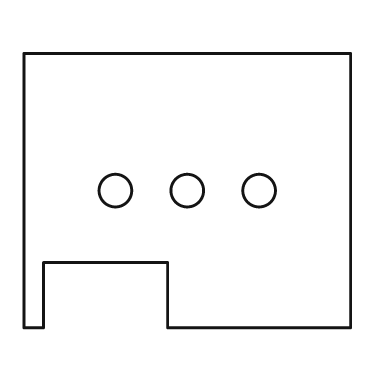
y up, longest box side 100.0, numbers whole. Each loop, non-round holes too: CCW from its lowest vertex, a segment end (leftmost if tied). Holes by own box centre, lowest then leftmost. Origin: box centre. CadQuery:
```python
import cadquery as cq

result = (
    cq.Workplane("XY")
    .moveTo(-50.0, -42.0)
    .lineTo(-44.0, -42.0)
    .lineTo(-44.0, -22.0)
    .lineTo(-6.0, -22.0)
    .lineTo(-6.0, -42.0)
    .lineTo(50.0, -42.0)
    .lineTo(50.0, 42.0)
    .lineTo(-50.0, 42.0)
    .close()
    .moveTo(-22.0, 0.0)
    .circle(5.0)
    .moveTo(0.0, 0.0)
    .circle(5.0)
    .moveTo(22.0, 0.0)
    .circle(5.0)
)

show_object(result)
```